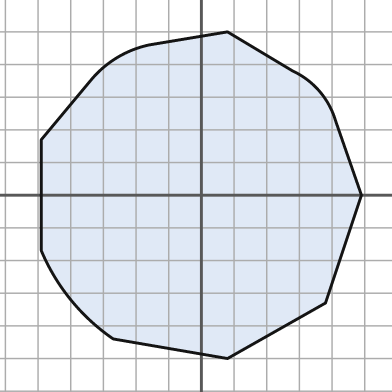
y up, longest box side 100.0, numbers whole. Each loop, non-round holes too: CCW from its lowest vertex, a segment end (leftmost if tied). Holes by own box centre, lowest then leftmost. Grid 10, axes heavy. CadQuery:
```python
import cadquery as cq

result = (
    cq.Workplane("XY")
    .moveTo(8.0, -50.0)
    .lineTo(38.0, -33.0)
    .lineTo(49.0, 0.0)
    .lineTo(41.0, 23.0)
    .threePointArc((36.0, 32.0), (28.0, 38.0))
    .lineTo(8.0, 50.0)
    .lineTo(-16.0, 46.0)
    .threePointArc((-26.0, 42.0), (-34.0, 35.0))
    .lineTo(-49.0, 17.0)
    .lineTo(-49.0, -17.0)
    .threePointArc((-40.0, -32.0), (-27.0, -44.0))
    .close()
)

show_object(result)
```